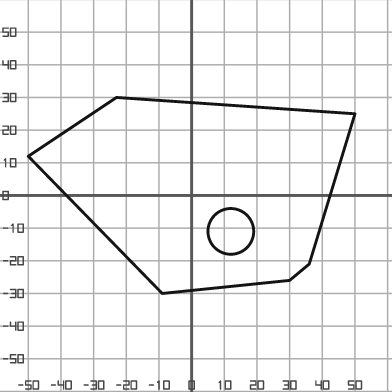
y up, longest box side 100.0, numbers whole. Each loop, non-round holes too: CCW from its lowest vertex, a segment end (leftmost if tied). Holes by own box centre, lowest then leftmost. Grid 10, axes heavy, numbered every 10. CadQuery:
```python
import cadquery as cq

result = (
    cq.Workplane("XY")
    .moveTo(-9.0, -30.0)
    .lineTo(30.0, -26.0)
    .lineTo(36.0, -21.0)
    .lineTo(50.0, 25.0)
    .lineTo(-23.0, 30.0)
    .lineTo(-50.0, 12.0)
    .close()
    .moveTo(12.0, -11.0)
    .circle(7.0)
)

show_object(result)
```